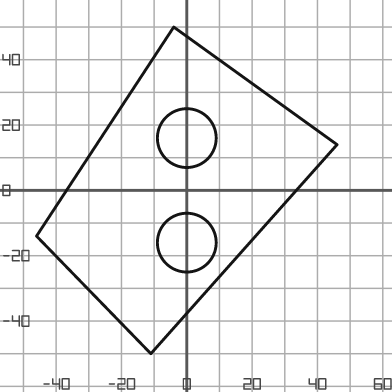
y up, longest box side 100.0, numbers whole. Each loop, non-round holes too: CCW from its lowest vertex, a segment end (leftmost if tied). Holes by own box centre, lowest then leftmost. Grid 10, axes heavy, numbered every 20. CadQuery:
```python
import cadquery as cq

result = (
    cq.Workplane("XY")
    .moveTo(-11.0, -50.0)
    .lineTo(46.0, 14.0)
    .lineTo(-4.0, 50.0)
    .lineTo(-46.0, -14.0)
    .close()
    .moveTo(0.0, -16.0)
    .circle(9.0)
    .moveTo(0.0, 16.0)
    .circle(9.0)
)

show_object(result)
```